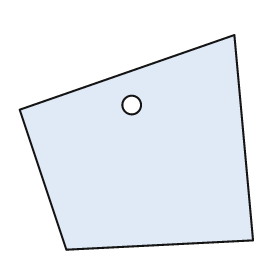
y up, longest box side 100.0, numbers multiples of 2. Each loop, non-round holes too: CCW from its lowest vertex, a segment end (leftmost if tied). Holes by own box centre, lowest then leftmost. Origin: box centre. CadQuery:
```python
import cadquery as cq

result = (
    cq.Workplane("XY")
    .moveTo(-30.0, -46.0)
    .lineTo(50.0, -42.0)
    .lineTo(42.0, 46.0)
    .lineTo(-50.0, 14.0)
    .close()
    .moveTo(-2.0, 16.0)
    .circle(4.0)
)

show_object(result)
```